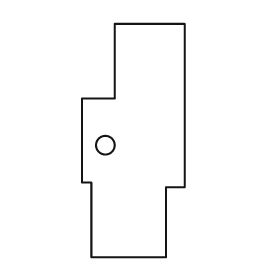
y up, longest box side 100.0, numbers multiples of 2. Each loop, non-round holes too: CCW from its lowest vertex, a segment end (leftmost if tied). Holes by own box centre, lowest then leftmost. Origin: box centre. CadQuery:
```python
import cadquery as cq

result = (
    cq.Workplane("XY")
    .moveTo(-18.0, -50.0)
    .lineTo(14.0, -50.0)
    .lineTo(14.0, -20.0)
    .lineTo(22.0, -20.0)
    .lineTo(22.0, 50.0)
    .lineTo(-8.0, 50.0)
    .lineTo(-8.0, 18.0)
    .lineTo(-22.0, 18.0)
    .lineTo(-22.0, -18.0)
    .lineTo(-18.0, -18.0)
    .close()
    .moveTo(-12.0, -2.0)
    .circle(4.0)
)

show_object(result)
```